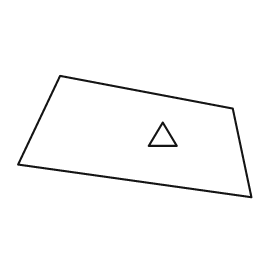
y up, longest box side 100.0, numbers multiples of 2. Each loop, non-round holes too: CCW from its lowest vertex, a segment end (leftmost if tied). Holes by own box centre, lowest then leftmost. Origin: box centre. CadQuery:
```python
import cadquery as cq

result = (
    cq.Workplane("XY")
    .moveTo(50.0, -26.0)
    .lineTo(42.0, 12.0)
    .lineTo(-32.0, 26.0)
    .lineTo(-50.0, -12.0)
    .close()
    .moveTo(6.0, -4.0)
    .lineTo(18.0, -4.0)
    .lineTo(12.0, 6.0)
    .close()
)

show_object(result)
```